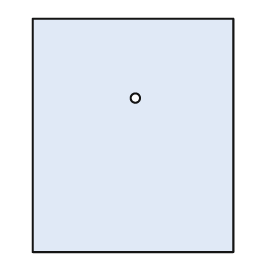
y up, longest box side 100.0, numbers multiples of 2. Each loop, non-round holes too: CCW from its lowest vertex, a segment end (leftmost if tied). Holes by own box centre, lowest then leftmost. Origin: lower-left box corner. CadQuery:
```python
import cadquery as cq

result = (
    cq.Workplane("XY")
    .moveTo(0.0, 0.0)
    .lineTo(86.0, 0.0)
    .lineTo(86.0, 100.0)
    .lineTo(0.0, 100.0)
    .close()
    .moveTo(44.0, 66.0)
    .circle(2.0)
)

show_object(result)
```